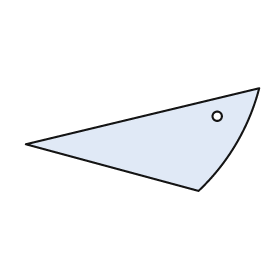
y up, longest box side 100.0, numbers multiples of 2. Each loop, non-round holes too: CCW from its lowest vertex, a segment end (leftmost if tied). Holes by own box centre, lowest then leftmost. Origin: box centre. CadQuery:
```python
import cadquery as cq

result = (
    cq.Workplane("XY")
    .moveTo(24.0, -22.0)
    .threePointArc((40.0, -2.0), (50.0, 22.0))
    .lineTo(-50.0, -2.0)
    .close()
    .moveTo(32.0, 10.0)
    .circle(2.0)
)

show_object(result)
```